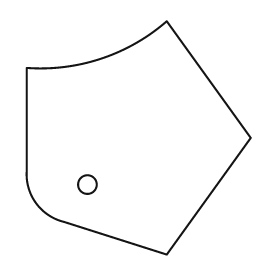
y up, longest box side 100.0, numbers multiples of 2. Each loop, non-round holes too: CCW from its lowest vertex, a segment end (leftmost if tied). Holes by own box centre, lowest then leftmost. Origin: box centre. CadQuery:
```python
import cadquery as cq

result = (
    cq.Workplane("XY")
    .moveTo(12.0, -50.0)
    .lineTo(48.0, 0.0)
    .lineTo(12.0, 50.0)
    .threePointArc((-16.0, 34.0), (-48.0, 30.0))
    .lineTo(-48.0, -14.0)
    .threePointArc((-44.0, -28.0), (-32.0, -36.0))
    .close()
    .moveTo(-22.0, -20.0)
    .circle(4.0)
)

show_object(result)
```